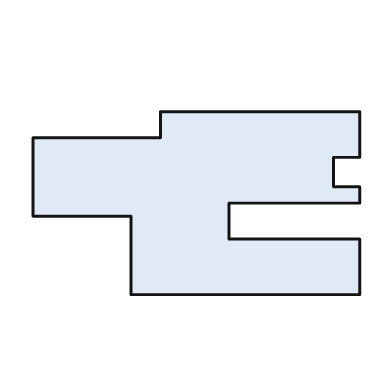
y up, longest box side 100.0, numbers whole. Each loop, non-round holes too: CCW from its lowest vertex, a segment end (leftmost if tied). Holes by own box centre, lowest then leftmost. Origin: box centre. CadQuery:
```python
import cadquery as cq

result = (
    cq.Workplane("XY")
    .moveTo(-20.0, -28.0)
    .lineTo(50.0, -28.0)
    .lineTo(50.0, -11.0)
    .lineTo(10.0, -11.0)
    .lineTo(10.0, 0.0)
    .lineTo(50.0, 0.0)
    .lineTo(50.0, 5.0)
    .lineTo(42.0, 5.0)
    .lineTo(42.0, 14.0)
    .lineTo(50.0, 14.0)
    .lineTo(50.0, 28.0)
    .lineTo(-11.0, 28.0)
    .lineTo(-11.0, 20.0)
    .lineTo(-50.0, 20.0)
    .lineTo(-50.0, -4.0)
    .lineTo(-20.0, -4.0)
    .close()
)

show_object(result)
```